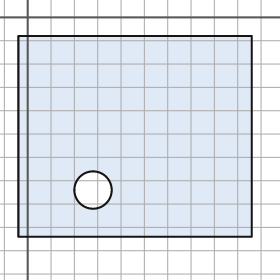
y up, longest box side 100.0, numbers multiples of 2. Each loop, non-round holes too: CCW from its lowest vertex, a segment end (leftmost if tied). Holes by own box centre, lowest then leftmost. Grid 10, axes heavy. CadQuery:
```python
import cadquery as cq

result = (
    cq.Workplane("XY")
    .moveTo(-4.0, -94.0)
    .lineTo(96.0, -94.0)
    .lineTo(96.0, -8.0)
    .lineTo(-4.0, -8.0)
    .close()
    .moveTo(28.0, -74.0)
    .circle(8.0)
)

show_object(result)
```